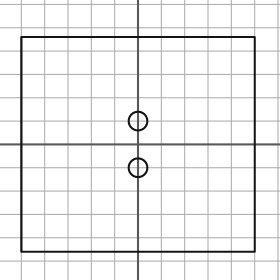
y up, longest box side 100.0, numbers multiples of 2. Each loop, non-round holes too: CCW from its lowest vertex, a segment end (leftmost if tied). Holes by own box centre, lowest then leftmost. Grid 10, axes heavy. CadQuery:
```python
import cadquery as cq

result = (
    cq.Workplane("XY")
    .moveTo(-50.0, -46.0)
    .lineTo(50.0, -46.0)
    .lineTo(50.0, 46.0)
    .lineTo(-50.0, 46.0)
    .close()
    .moveTo(0.0, -10.0)
    .circle(4.0)
    .moveTo(0.0, 10.0)
    .circle(4.0)
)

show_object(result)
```